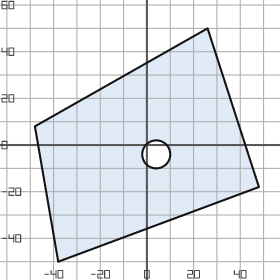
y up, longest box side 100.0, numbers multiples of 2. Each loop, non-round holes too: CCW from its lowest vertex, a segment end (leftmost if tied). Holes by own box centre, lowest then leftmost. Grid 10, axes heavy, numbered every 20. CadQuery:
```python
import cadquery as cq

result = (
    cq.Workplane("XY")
    .moveTo(-38.0, -50.0)
    .lineTo(48.0, -18.0)
    .lineTo(26.0, 50.0)
    .lineTo(-48.0, 8.0)
    .close()
    .moveTo(4.0, -4.0)
    .circle(6.0)
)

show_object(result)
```